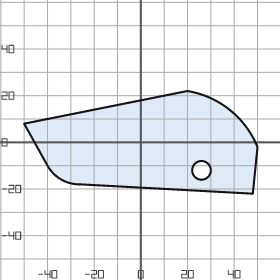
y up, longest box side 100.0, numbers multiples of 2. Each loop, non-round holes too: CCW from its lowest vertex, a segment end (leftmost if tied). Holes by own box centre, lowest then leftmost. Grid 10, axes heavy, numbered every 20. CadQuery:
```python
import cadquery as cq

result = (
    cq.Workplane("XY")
    .moveTo(48.0, -22.0)
    .lineTo(50.0, -2.0)
    .threePointArc((38.0, 14.0), (20.0, 22.0))
    .lineTo(-50.0, 8.0)
    .lineTo(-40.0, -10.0)
    .threePointArc((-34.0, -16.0), (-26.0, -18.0))
    .close()
    .moveTo(26.0, -12.0)
    .circle(4.0)
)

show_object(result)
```